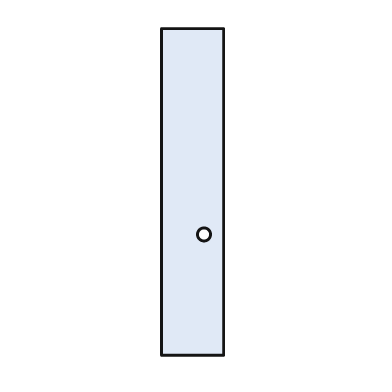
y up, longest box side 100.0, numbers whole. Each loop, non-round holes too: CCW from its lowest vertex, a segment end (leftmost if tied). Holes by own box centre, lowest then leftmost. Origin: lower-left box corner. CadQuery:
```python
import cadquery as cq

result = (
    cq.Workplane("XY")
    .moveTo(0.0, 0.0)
    .lineTo(19.0, 0.0)
    .lineTo(19.0, 100.0)
    .lineTo(0.0, 100.0)
    .close()
    .moveTo(13.0, 37.0)
    .circle(2.0)
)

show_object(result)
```